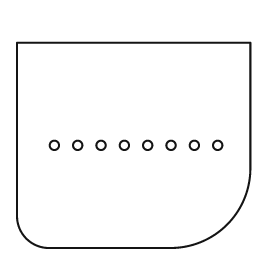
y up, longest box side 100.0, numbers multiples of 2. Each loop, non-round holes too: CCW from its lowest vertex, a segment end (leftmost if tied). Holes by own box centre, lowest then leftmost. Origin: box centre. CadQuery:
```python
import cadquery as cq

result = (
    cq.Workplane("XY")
    .moveTo(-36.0, -44.0)
    .lineTo(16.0, -44.0)
    .threePointArc((40.0, -34.0), (50.0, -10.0))
    .lineTo(50.0, 44.0)
    .lineTo(-50.0, 44.0)
    .lineTo(-50.0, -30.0)
    .threePointArc((-46.0, -40.0), (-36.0, -44.0))
    .close()
    .moveTo(-34.0, 0.0)
    .circle(2.0)
    .moveTo(-24.0, 0.0)
    .circle(2.0)
    .moveTo(-14.0, 0.0)
    .circle(2.0)
    .moveTo(-4.0, 0.0)
    .circle(2.0)
    .moveTo(6.0, 0.0)
    .circle(2.0)
    .moveTo(16.0, 0.0)
    .circle(2.0)
    .moveTo(26.0, 0.0)
    .circle(2.0)
    .moveTo(36.0, 0.0)
    .circle(2.0)
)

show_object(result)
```